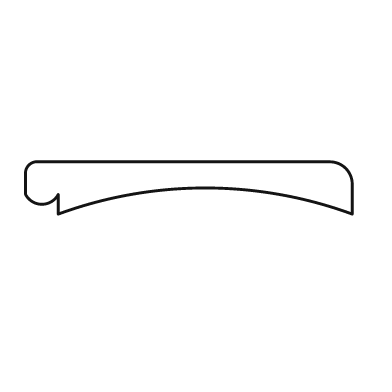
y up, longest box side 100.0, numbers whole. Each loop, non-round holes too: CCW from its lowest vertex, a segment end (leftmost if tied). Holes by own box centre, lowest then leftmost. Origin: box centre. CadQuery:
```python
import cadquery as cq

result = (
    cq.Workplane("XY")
    .moveTo(-40.0, -8.0)
    .threePointArc((5.0, 0.0), (50.0, -8.0))
    .lineTo(50.0, 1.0)
    .threePointArc((48.0, 6.0), (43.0, 8.0))
    .lineTo(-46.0, 8.0)
    .threePointArc((-49.0, 7.0), (-50.0, 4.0))
    .lineTo(-50.0, -2.0)
    .threePointArc((-45.0, -5.0), (-40.0, -2.0))
    .close()
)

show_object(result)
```